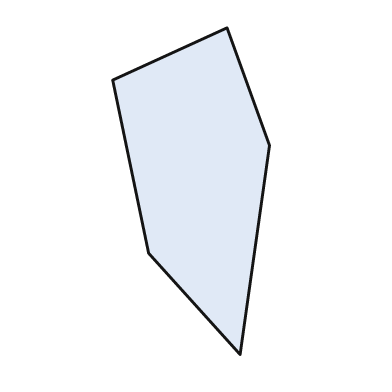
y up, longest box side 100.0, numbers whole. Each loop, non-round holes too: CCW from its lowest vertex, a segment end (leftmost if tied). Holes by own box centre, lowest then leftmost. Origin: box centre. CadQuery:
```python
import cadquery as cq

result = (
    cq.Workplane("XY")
    .moveTo(15.0, -50.0)
    .lineTo(24.0, 14.0)
    .lineTo(11.0, 50.0)
    .lineTo(-24.0, 34.0)
    .lineTo(-13.0, -19.0)
    .close()
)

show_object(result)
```